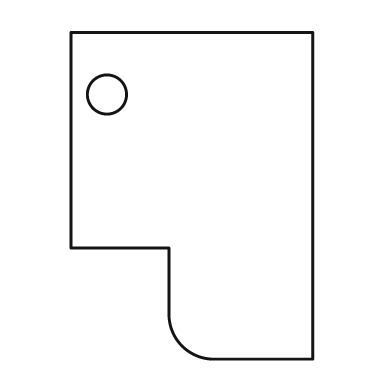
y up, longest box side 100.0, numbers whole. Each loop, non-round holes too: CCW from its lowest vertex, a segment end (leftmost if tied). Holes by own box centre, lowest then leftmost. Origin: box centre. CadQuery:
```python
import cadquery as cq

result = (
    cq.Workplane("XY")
    .moveTo(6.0, -50.0)
    .lineTo(37.0, -50.0)
    .lineTo(37.0, 50.0)
    .lineTo(-37.0, 50.0)
    .lineTo(-37.0, -16.0)
    .lineTo(-7.0, -16.0)
    .lineTo(-7.0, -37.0)
    .threePointArc((-3.0, -46.0), (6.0, -50.0))
    .close()
    .moveTo(-26.0, 31.0)
    .circle(6.0)
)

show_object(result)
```